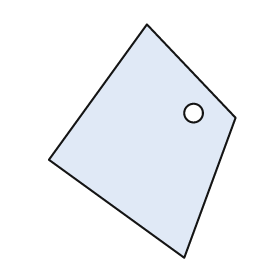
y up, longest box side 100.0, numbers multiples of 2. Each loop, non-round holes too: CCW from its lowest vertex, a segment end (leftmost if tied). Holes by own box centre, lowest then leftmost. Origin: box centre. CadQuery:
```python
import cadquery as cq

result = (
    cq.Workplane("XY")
    .moveTo(18.0, -50.0)
    .lineTo(40.0, 10.0)
    .lineTo(2.0, 50.0)
    .lineTo(-40.0, -8.0)
    .close()
    .moveTo(22.0, 12.0)
    .circle(4.0)
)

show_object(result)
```